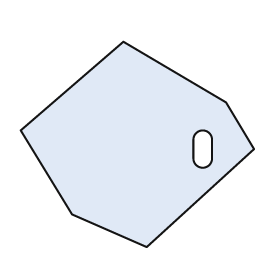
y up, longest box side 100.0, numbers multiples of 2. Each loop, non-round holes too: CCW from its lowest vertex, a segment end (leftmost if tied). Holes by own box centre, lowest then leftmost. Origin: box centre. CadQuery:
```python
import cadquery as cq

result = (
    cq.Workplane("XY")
    .moveTo(4.0, -44.0)
    .lineTo(50.0, -2.0)
    .lineTo(38.0, 18.0)
    .lineTo(-6.0, 44.0)
    .lineTo(-50.0, 6.0)
    .lineTo(-28.0, -30.0)
    .close()
    .moveTo(24.0, -6.0)
    .threePointArc((28.0, -10.0), (32.0, -6.0))
    .lineTo(32.0, 2.0)
    .threePointArc((28.0, 6.0), (24.0, 2.0))
    .close()
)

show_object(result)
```